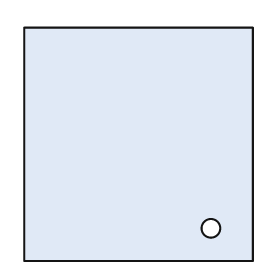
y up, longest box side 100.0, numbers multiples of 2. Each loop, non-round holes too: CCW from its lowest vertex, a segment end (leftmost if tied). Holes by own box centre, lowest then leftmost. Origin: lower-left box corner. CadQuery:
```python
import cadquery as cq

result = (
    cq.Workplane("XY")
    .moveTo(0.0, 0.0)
    .lineTo(98.0, 0.0)
    .lineTo(98.0, 100.0)
    .lineTo(0.0, 100.0)
    .close()
    .moveTo(80.0, 14.0)
    .circle(4.0)
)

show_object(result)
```